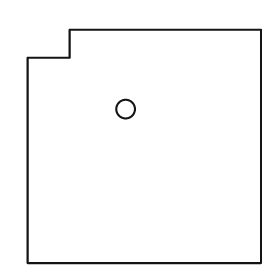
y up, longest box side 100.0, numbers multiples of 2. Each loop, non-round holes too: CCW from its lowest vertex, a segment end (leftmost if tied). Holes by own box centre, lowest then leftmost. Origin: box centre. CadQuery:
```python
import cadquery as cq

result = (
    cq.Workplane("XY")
    .moveTo(-50.0, -50.0)
    .lineTo(50.0, -50.0)
    .lineTo(50.0, 50.0)
    .lineTo(-32.0, 50.0)
    .lineTo(-32.0, 38.0)
    .lineTo(-50.0, 38.0)
    .close()
    .moveTo(-8.0, 16.0)
    .circle(4.0)
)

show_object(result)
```